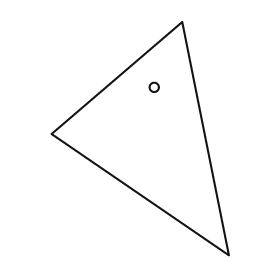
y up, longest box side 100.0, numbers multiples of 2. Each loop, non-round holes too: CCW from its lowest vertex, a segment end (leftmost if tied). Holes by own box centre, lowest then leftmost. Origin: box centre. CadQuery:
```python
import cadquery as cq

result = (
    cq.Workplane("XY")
    .moveTo(38.0, -50.0)
    .lineTo(18.0, 50.0)
    .lineTo(-38.0, 2.0)
    .close()
    .moveTo(6.0, 22.0)
    .circle(2.0)
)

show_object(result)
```